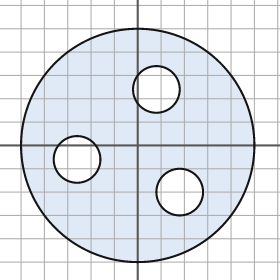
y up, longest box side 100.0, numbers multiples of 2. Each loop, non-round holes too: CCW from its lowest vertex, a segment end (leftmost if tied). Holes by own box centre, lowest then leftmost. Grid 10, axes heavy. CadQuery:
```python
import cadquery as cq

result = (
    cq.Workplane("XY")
    .moveTo(0.0, 0.0)
    .circle(50.0)
    .moveTo(18.0, -20.0)
    .circle(10.0)
    .moveTo(-26.0, -6.0)
    .circle(10.0)
    .moveTo(8.0, 24.0)
    .circle(10.0)
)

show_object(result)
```